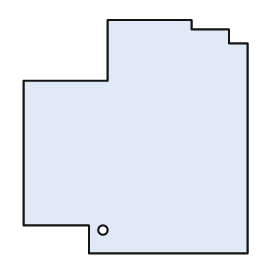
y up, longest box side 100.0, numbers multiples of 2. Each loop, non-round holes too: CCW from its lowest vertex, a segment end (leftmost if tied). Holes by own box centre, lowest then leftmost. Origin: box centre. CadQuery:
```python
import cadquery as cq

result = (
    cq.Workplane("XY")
    .moveTo(-20.0, -50.0)
    .lineTo(48.0, -50.0)
    .lineTo(48.0, 40.0)
    .lineTo(40.0, 40.0)
    .lineTo(40.0, 46.0)
    .lineTo(24.0, 46.0)
    .lineTo(24.0, 50.0)
    .lineTo(-12.0, 50.0)
    .lineTo(-12.0, 24.0)
    .lineTo(-48.0, 24.0)
    .lineTo(-48.0, -38.0)
    .lineTo(-20.0, -38.0)
    .close()
    .moveTo(-14.0, -40.0)
    .circle(2.0)
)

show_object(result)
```